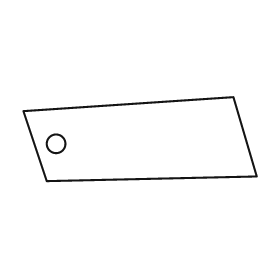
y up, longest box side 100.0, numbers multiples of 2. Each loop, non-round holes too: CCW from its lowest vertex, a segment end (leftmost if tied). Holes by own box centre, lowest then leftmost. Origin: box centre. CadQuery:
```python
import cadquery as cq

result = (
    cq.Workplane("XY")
    .moveTo(-40.0, -18.0)
    .lineTo(50.0, -16.0)
    .lineTo(40.0, 18.0)
    .lineTo(-50.0, 12.0)
    .close()
    .moveTo(-36.0, -2.0)
    .circle(4.0)
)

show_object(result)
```